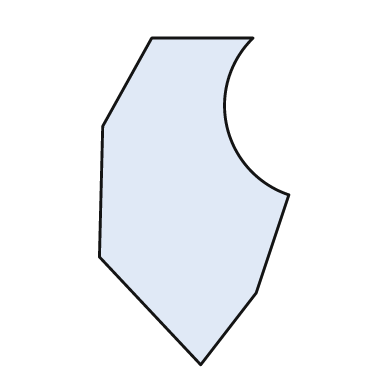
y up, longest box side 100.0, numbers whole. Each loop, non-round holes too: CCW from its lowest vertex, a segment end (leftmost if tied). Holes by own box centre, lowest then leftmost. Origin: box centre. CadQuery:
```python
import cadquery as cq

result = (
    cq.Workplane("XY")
    .moveTo(2.0, -50.0)
    .lineTo(19.0, -28.0)
    .lineTo(29.0, 2.0)
    .threePointArc((10.0, 23.0), (18.0, 50.0))
    .lineTo(-13.0, 50.0)
    .lineTo(-28.0, 23.0)
    .lineTo(-29.0, -17.0)
    .close()
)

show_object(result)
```